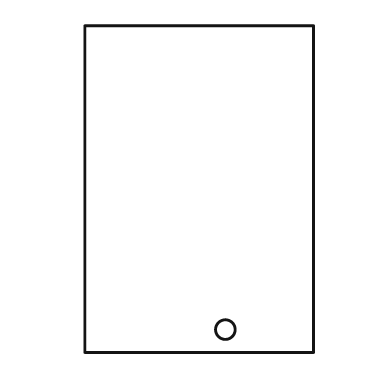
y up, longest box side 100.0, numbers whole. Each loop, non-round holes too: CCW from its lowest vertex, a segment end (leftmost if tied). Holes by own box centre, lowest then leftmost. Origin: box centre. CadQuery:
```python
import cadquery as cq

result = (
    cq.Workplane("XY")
    .moveTo(-35.0, -50.0)
    .lineTo(35.0, -50.0)
    .lineTo(35.0, 50.0)
    .lineTo(-35.0, 50.0)
    .close()
    .moveTo(8.0, -43.0)
    .circle(3.0)
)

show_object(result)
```